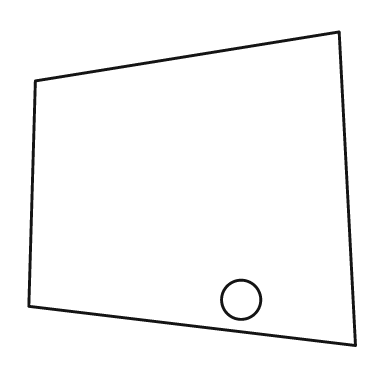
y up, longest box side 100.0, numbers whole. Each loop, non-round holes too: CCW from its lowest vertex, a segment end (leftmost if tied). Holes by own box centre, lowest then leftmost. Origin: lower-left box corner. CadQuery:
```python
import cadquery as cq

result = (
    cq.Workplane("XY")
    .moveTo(100.0, 0.0)
    .lineTo(95.0, 96.0)
    .lineTo(2.0, 81.0)
    .lineTo(0.0, 12.0)
    .close()
    .moveTo(65.0, 14.0)
    .circle(6.0)
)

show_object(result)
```